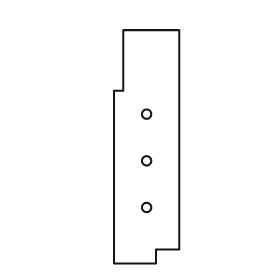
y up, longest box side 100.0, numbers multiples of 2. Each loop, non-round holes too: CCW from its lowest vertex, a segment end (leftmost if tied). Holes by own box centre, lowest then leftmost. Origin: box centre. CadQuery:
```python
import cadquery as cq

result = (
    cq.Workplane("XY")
    .moveTo(-14.0, -50.0)
    .lineTo(4.0, -50.0)
    .lineTo(4.0, -44.0)
    .lineTo(14.0, -44.0)
    .lineTo(14.0, 50.0)
    .lineTo(-10.0, 50.0)
    .lineTo(-10.0, 24.0)
    .lineTo(-14.0, 24.0)
    .close()
    .moveTo(0.0, -26.0)
    .circle(2.0)
    .moveTo(0.0, -6.0)
    .circle(2.0)
    .moveTo(0.0, 14.0)
    .circle(2.0)
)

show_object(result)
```